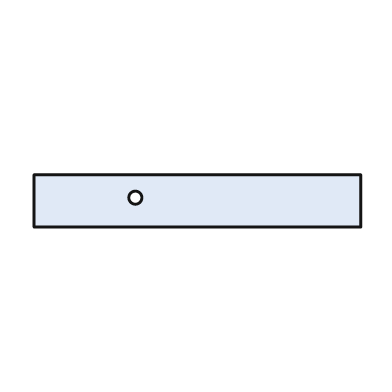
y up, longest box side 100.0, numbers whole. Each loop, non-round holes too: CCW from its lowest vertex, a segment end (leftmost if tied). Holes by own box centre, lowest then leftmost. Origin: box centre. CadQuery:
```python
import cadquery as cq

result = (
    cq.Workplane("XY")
    .moveTo(-50.0, -8.0)
    .lineTo(50.0, -8.0)
    .lineTo(50.0, 8.0)
    .lineTo(-50.0, 8.0)
    .close()
    .moveTo(-19.0, 1.0)
    .circle(2.0)
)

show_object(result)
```